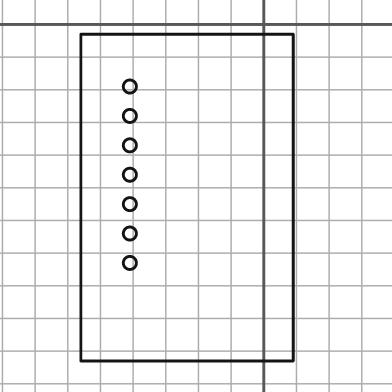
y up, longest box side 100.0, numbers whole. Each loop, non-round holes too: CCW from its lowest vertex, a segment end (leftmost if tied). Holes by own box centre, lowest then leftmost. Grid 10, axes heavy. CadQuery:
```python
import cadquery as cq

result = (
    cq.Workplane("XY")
    .moveTo(-56.0, -103.0)
    .lineTo(9.0, -103.0)
    .lineTo(9.0, -3.0)
    .lineTo(-56.0, -3.0)
    .close()
    .moveTo(-41.0, -73.0)
    .circle(2.0)
    .moveTo(-41.0, -64.0)
    .circle(2.0)
    .moveTo(-41.0, -55.0)
    .circle(2.0)
    .moveTo(-41.0, -46.0)
    .circle(2.0)
    .moveTo(-41.0, -37.0)
    .circle(2.0)
    .moveTo(-41.0, -28.0)
    .circle(2.0)
    .moveTo(-41.0, -19.0)
    .circle(2.0)
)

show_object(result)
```